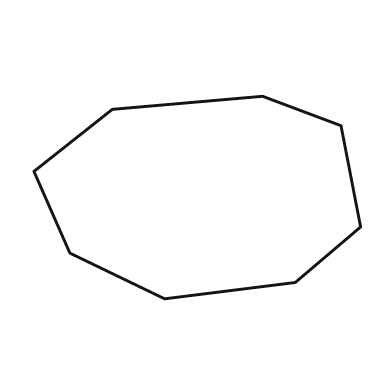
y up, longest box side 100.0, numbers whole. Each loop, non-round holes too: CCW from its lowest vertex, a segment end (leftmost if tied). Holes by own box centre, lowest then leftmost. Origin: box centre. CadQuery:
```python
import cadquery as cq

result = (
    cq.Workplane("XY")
    .moveTo(-10.0, -31.0)
    .lineTo(30.0, -26.0)
    .lineTo(50.0, -9.0)
    .lineTo(44.0, 22.0)
    .lineTo(20.0, 31.0)
    .lineTo(-26.0, 27.0)
    .lineTo(-50.0, 8.0)
    .lineTo(-39.0, -17.0)
    .close()
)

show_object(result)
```